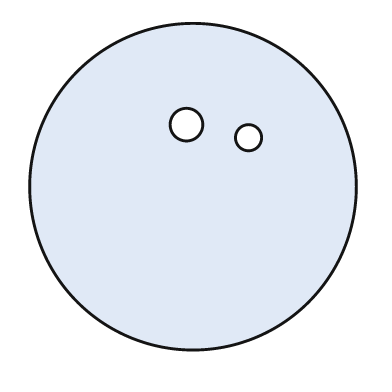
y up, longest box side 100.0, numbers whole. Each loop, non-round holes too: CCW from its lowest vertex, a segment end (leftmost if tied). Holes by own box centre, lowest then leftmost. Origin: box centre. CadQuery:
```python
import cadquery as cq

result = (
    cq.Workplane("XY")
    .moveTo(0.0, 0.0)
    .circle(50.0)
    .moveTo(17.0, 15.0)
    .circle(4.0)
    .moveTo(-2.0, 19.0)
    .circle(5.0)
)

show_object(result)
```